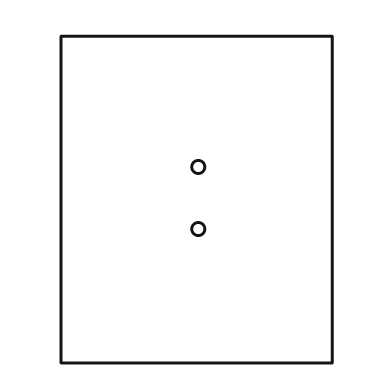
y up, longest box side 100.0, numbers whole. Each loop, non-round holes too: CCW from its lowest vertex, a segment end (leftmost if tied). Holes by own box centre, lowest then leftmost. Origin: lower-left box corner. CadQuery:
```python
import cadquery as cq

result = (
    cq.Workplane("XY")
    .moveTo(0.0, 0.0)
    .lineTo(83.0, 0.0)
    .lineTo(83.0, 100.0)
    .lineTo(0.0, 100.0)
    .close()
    .moveTo(42.0, 41.0)
    .circle(2.0)
    .moveTo(42.0, 60.0)
    .circle(2.0)
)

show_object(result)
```